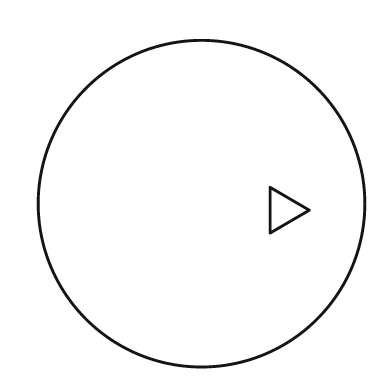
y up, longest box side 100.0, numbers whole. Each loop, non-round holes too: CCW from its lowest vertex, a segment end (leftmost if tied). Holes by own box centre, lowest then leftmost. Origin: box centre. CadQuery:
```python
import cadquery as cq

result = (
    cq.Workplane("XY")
    .moveTo(0.0, 0.0)
    .circle(50.0)
    .moveTo(21.0, -9.0)
    .lineTo(33.0, -2.0)
    .lineTo(21.0, 5.0)
    .close()
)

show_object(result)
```